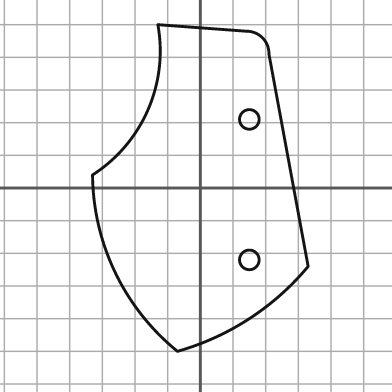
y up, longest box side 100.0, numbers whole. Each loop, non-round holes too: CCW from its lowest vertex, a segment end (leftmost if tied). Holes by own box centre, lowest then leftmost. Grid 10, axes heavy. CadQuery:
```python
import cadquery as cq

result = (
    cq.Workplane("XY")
    .moveTo(-7.0, -50.0)
    .threePointArc((15.0, -40.0), (33.0, -24.0))
    .lineTo(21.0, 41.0)
    .threePointArc((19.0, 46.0), (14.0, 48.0))
    .lineTo(-13.0, 50.0)
    .threePointArc((-16.0, 24.0), (-33.0, 4.0))
    .threePointArc((-26.0, -26.0), (-7.0, -50.0))
    .close()
    .moveTo(15.0, -22.0)
    .circle(3.0)
    .moveTo(15.0, 21.0)
    .circle(3.0)
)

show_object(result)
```